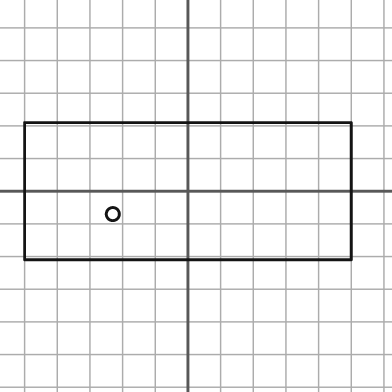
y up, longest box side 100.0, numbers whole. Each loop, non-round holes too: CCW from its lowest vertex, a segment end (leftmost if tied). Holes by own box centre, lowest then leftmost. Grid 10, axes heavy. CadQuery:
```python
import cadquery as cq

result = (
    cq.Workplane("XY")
    .moveTo(-50.0, -21.0)
    .lineTo(50.0, -21.0)
    .lineTo(50.0, 21.0)
    .lineTo(-50.0, 21.0)
    .close()
    .moveTo(-23.0, -7.0)
    .circle(2.0)
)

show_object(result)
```